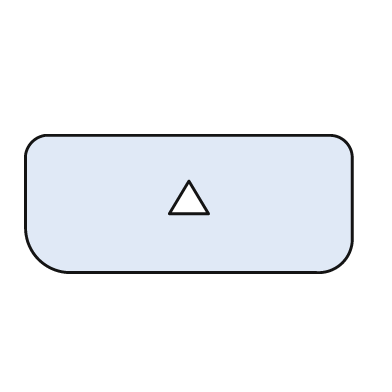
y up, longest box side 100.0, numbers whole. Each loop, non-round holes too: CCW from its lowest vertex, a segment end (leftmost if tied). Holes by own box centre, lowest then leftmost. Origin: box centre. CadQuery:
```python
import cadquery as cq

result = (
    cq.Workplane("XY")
    .moveTo(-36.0, -21.0)
    .lineTo(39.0, -21.0)
    .threePointArc((47.0, -18.0), (50.0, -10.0))
    .lineTo(50.0, 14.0)
    .threePointArc((48.0, 19.0), (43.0, 21.0))
    .lineTo(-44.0, 21.0)
    .threePointArc((-48.0, 19.0), (-50.0, 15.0))
    .lineTo(-50.0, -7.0)
    .threePointArc((-46.0, -17.0), (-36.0, -21.0))
    .close()
    .moveTo(-6.0, -3.0)
    .lineTo(6.0, -3.0)
    .lineTo(0.0, 7.0)
    .close()
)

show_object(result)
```